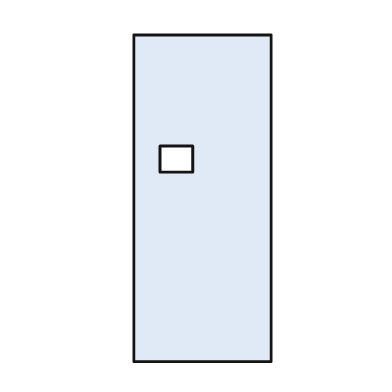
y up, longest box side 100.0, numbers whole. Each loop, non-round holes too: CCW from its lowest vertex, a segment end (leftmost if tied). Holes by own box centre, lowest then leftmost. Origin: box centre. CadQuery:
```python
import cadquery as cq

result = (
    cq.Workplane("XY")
    .moveTo(-21.0, -50.0)
    .lineTo(21.0, -50.0)
    .lineTo(21.0, 50.0)
    .lineTo(-21.0, 50.0)
    .close()
    .moveTo(-13.0, 8.0)
    .lineTo(-3.0, 8.0)
    .lineTo(-3.0, 16.0)
    .lineTo(-13.0, 16.0)
    .close()
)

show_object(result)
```